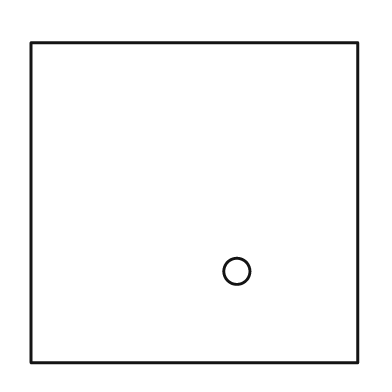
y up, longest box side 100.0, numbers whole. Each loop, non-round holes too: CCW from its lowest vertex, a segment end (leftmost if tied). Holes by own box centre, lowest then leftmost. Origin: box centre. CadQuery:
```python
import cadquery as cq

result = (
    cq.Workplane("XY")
    .moveTo(-50.0, -49.0)
    .lineTo(50.0, -49.0)
    .lineTo(50.0, 49.0)
    .lineTo(-50.0, 49.0)
    .close()
    .moveTo(13.0, -21.0)
    .circle(4.0)
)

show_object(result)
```